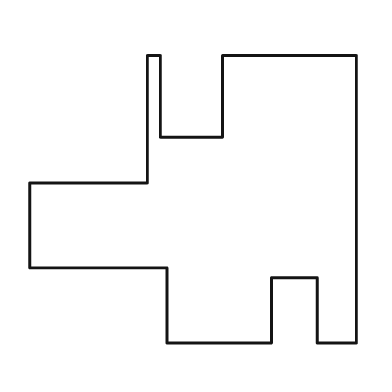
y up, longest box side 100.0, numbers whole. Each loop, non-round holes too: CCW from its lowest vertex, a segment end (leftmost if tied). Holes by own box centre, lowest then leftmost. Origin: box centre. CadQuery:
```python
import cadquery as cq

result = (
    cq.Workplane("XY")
    .moveTo(-8.0, -44.0)
    .lineTo(24.0, -44.0)
    .lineTo(24.0, -24.0)
    .lineTo(38.0, -24.0)
    .lineTo(38.0, -44.0)
    .lineTo(50.0, -44.0)
    .lineTo(50.0, 44.0)
    .lineTo(9.0, 44.0)
    .lineTo(9.0, 19.0)
    .lineTo(-10.0, 19.0)
    .lineTo(-10.0, 44.0)
    .lineTo(-14.0, 44.0)
    .lineTo(-14.0, 5.0)
    .lineTo(-50.0, 5.0)
    .lineTo(-50.0, -21.0)
    .lineTo(-8.0, -21.0)
    .close()
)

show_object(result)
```